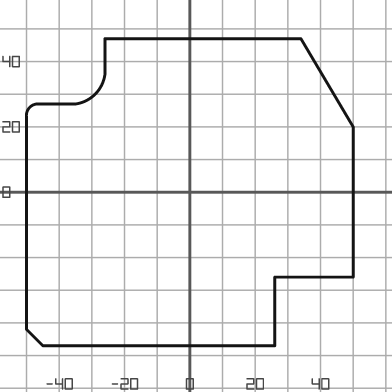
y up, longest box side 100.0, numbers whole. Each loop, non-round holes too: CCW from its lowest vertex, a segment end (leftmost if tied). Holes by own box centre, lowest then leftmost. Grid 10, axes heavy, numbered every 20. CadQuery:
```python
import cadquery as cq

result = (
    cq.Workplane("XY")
    .moveTo(-45.0, -47.0)
    .lineTo(26.0, -47.0)
    .lineTo(26.0, -26.0)
    .lineTo(50.0, -26.0)
    .lineTo(50.0, 20.0)
    .lineTo(34.0, 47.0)
    .lineTo(-26.0, 47.0)
    .lineTo(-26.0, 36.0)
    .threePointArc((-29.0, 30.0), (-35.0, 27.0))
    .lineTo(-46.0, 27.0)
    .threePointArc((-49.0, 26.0), (-50.0, 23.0))
    .lineTo(-50.0, -42.0)
    .close()
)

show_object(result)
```